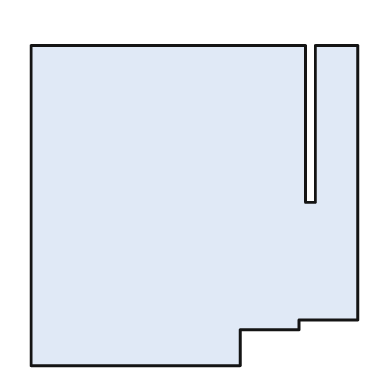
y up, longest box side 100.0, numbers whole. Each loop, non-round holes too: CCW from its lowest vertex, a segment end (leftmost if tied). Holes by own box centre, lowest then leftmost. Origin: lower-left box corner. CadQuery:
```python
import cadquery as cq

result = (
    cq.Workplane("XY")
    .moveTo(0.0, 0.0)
    .lineTo(64.0, 0.0)
    .lineTo(64.0, 11.0)
    .lineTo(82.0, 11.0)
    .lineTo(82.0, 14.0)
    .lineTo(100.0, 14.0)
    .lineTo(100.0, 98.0)
    .lineTo(87.0, 98.0)
    .lineTo(87.0, 50.0)
    .lineTo(84.0, 50.0)
    .lineTo(84.0, 98.0)
    .lineTo(0.0, 98.0)
    .close()
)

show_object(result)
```